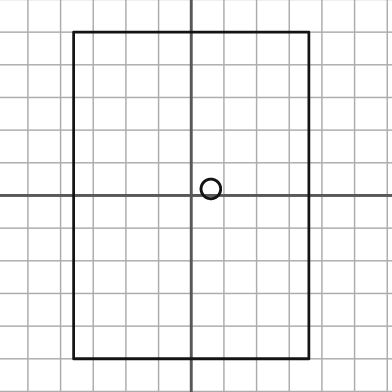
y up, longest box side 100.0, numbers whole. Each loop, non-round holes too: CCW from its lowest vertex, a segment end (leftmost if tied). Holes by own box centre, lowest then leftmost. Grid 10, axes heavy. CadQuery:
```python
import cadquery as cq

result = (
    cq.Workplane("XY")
    .moveTo(-36.0, -50.0)
    .lineTo(36.0, -50.0)
    .lineTo(36.0, 50.0)
    .lineTo(-36.0, 50.0)
    .close()
    .moveTo(6.0, 2.0)
    .circle(3.0)
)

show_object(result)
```